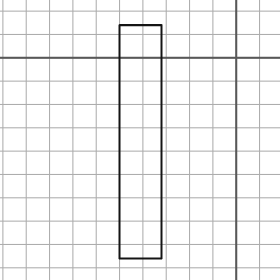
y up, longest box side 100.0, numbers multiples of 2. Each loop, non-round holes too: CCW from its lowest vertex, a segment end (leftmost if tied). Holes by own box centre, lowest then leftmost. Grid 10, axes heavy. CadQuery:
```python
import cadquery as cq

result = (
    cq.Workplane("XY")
    .moveTo(-50.0, -86.0)
    .lineTo(-32.0, -86.0)
    .lineTo(-32.0, 14.0)
    .lineTo(-50.0, 14.0)
    .close()
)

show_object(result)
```